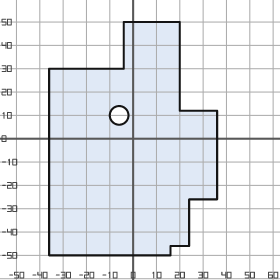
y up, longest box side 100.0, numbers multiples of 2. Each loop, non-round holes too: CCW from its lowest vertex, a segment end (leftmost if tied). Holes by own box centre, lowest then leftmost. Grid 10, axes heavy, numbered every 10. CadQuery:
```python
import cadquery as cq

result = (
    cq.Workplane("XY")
    .moveTo(-36.0, -50.0)
    .lineTo(16.0, -50.0)
    .lineTo(16.0, -46.0)
    .lineTo(24.0, -46.0)
    .lineTo(24.0, -26.0)
    .lineTo(36.0, -26.0)
    .lineTo(36.0, 12.0)
    .lineTo(20.0, 12.0)
    .lineTo(20.0, 50.0)
    .lineTo(-4.0, 50.0)
    .lineTo(-4.0, 30.0)
    .lineTo(-36.0, 30.0)
    .close()
    .moveTo(-6.0, 10.0)
    .circle(4.0)
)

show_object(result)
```